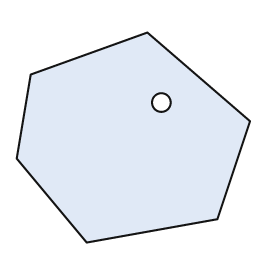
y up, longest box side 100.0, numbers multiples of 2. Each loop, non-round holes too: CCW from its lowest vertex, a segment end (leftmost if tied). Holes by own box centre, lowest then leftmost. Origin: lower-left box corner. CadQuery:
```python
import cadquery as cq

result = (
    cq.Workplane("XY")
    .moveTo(30.0, 0.0)
    .lineTo(86.0, 10.0)
    .lineTo(100.0, 52.0)
    .lineTo(56.0, 90.0)
    .lineTo(6.0, 72.0)
    .lineTo(0.0, 36.0)
    .close()
    .moveTo(62.0, 60.0)
    .circle(4.0)
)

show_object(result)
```